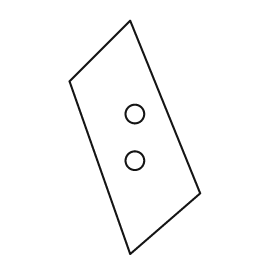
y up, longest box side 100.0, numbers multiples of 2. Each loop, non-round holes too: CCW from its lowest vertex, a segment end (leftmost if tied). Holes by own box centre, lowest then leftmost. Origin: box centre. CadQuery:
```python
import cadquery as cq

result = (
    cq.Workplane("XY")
    .moveTo(-2.0, -50.0)
    .lineTo(28.0, -24.0)
    .lineTo(-2.0, 50.0)
    .lineTo(-28.0, 24.0)
    .close()
    .moveTo(0.0, -10.0)
    .circle(4.0)
    .moveTo(0.0, 10.0)
    .circle(4.0)
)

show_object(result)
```